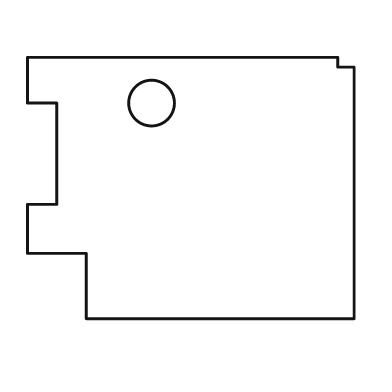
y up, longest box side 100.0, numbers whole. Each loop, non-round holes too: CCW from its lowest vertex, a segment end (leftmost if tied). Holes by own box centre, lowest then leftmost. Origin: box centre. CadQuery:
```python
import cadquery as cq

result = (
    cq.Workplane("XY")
    .moveTo(-32.0, -40.0)
    .lineTo(50.0, -40.0)
    .lineTo(50.0, 37.0)
    .lineTo(45.0, 37.0)
    .lineTo(45.0, 40.0)
    .lineTo(-50.0, 40.0)
    .lineTo(-50.0, 26.0)
    .lineTo(-41.0, 26.0)
    .lineTo(-41.0, -5.0)
    .lineTo(-50.0, -5.0)
    .lineTo(-50.0, -20.0)
    .lineTo(-32.0, -20.0)
    .close()
    .moveTo(-12.0, 26.0)
    .circle(7.0)
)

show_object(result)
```